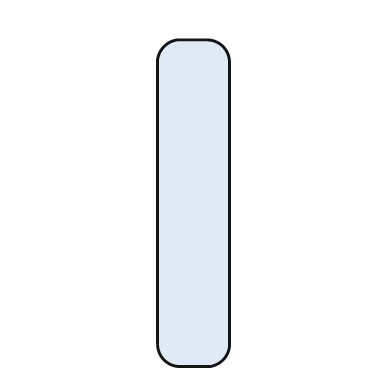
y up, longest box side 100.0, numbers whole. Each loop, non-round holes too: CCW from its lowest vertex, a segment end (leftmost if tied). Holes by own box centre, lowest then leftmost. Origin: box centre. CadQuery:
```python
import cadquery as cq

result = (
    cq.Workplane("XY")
    .moveTo(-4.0, -50.0)
    .lineTo(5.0, -50.0)
    .threePointArc((9.0, -48.0), (11.0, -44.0))
    .lineTo(11.0, 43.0)
    .threePointArc((9.0, 48.0), (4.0, 50.0))
    .lineTo(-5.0, 50.0)
    .threePointArc((-9.0, 48.0), (-11.0, 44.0))
    .lineTo(-11.0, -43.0)
    .threePointArc((-9.0, -48.0), (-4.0, -50.0))
    .close()
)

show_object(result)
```